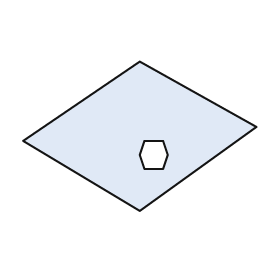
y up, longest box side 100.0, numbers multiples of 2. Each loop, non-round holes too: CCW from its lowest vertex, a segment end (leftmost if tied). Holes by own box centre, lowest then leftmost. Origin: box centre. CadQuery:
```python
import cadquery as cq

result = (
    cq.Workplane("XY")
    .moveTo(0.0, -32.0)
    .lineTo(50.0, 4.0)
    .lineTo(0.0, 32.0)
    .lineTo(-50.0, -2.0)
    .close()
    .moveTo(2.0, -14.0)
    .lineTo(10.0, -14.0)
    .lineTo(12.0, -8.0)
    .lineTo(10.0, -2.0)
    .lineTo(2.0, -2.0)
    .lineTo(0.0, -8.0)
    .close()
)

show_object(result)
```